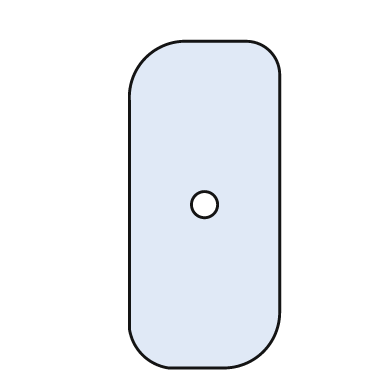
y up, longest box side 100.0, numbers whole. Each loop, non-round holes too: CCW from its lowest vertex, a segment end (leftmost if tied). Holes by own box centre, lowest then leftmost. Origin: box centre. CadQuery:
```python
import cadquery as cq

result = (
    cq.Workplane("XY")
    .moveTo(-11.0, -50.0)
    .lineTo(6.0, -50.0)
    .threePointArc((18.0, -45.0), (23.0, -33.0))
    .lineTo(23.0, 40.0)
    .threePointArc((20.0, 47.0), (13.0, 50.0))
    .lineTo(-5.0, 50.0)
    .threePointArc((-18.0, 45.0), (-23.0, 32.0))
    .lineTo(-23.0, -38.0)
    .threePointArc((-19.0, -46.0), (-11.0, -50.0))
    .close()
    .moveTo(0.0, 0.0)
    .circle(4.0)
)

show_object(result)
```